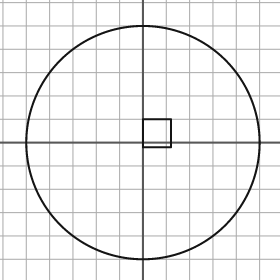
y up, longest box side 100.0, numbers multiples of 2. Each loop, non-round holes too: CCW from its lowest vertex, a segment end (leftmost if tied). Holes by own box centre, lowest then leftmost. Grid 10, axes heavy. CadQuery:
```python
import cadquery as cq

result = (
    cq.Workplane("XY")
    .moveTo(0.0, 0.0)
    .circle(50.0)
    .moveTo(0.0, -2.0)
    .lineTo(12.0, -2.0)
    .lineTo(12.0, 10.0)
    .lineTo(0.0, 10.0)
    .close()
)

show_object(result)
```